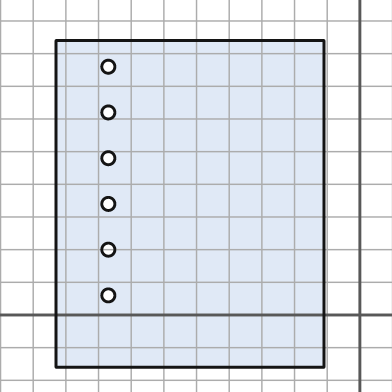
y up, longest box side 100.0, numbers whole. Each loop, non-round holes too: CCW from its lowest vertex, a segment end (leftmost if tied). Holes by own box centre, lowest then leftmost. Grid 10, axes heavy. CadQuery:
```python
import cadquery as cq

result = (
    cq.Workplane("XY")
    .moveTo(-93.0, -16.0)
    .lineTo(-11.0, -16.0)
    .lineTo(-11.0, 84.0)
    .lineTo(-93.0, 84.0)
    .close()
    .moveTo(-77.0, 6.0)
    .circle(2.0)
    .moveTo(-77.0, 20.0)
    .circle(2.0)
    .moveTo(-77.0, 34.0)
    .circle(2.0)
    .moveTo(-77.0, 48.0)
    .circle(2.0)
    .moveTo(-77.0, 62.0)
    .circle(2.0)
    .moveTo(-77.0, 76.0)
    .circle(2.0)
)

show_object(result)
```